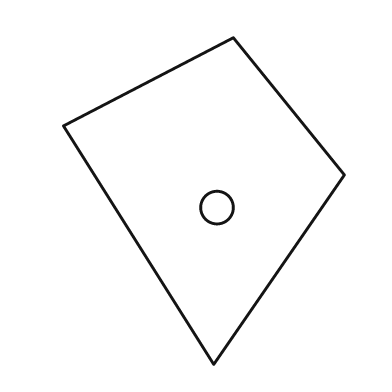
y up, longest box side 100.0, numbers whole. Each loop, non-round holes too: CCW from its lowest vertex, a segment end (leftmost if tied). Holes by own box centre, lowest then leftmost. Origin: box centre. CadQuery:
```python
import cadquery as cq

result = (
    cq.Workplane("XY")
    .moveTo(3.0, -50.0)
    .lineTo(43.0, 8.0)
    .lineTo(9.0, 50.0)
    .lineTo(-43.0, 23.0)
    .close()
    .moveTo(4.0, -2.0)
    .circle(5.0)
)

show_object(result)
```